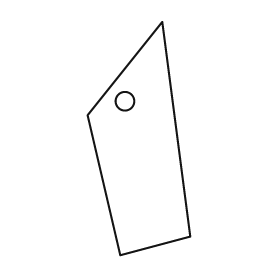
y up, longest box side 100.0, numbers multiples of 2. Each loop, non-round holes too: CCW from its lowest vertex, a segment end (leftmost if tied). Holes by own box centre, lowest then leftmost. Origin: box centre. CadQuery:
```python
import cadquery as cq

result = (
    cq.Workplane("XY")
    .moveTo(-8.0, -50.0)
    .lineTo(22.0, -42.0)
    .lineTo(10.0, 50.0)
    .lineTo(-22.0, 10.0)
    .close()
    .moveTo(-6.0, 16.0)
    .circle(4.0)
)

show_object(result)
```